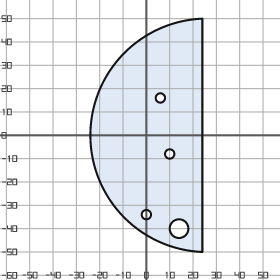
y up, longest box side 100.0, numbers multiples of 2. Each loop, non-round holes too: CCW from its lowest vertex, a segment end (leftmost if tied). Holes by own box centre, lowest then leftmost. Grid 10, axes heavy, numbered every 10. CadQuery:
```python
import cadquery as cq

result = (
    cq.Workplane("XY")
    .moveTo(24.0, -50.0)
    .lineTo(24.0, 50.0)
    .threePointArc((-24.0, 0.0), (24.0, -50.0))
    .close()
    .moveTo(14.0, -40.0)
    .circle(4.0)
    .moveTo(0.0, -34.0)
    .circle(2.0)
    .moveTo(10.0, -8.0)
    .circle(2.0)
    .moveTo(6.0, 16.0)
    .circle(2.0)
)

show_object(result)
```